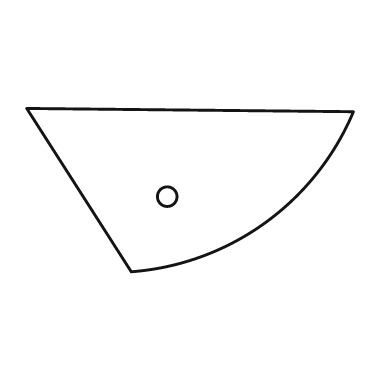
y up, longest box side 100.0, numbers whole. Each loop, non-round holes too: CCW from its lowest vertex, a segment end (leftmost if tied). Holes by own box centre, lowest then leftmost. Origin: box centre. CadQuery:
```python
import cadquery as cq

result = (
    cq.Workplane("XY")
    .moveTo(-18.0, -25.0)
    .threePointArc((23.0, -10.0), (50.0, 24.0))
    .lineTo(-50.0, 25.0)
    .close()
    .moveTo(-7.0, -2.0)
    .circle(3.0)
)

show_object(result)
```